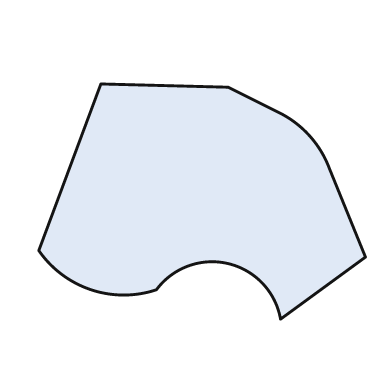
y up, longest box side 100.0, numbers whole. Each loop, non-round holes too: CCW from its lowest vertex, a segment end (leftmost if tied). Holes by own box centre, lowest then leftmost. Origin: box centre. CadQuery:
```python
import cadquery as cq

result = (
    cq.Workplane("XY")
    .moveTo(24.0, -36.0)
    .lineTo(50.0, -17.0)
    .lineTo(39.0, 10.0)
    .threePointArc((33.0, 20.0), (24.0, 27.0))
    .lineTo(8.0, 35.0)
    .lineTo(-31.0, 36.0)
    .lineTo(-50.0, -15.0)
    .threePointArc((-34.0, -27.0), (-14.0, -27.0))
    .threePointArc((8.0, -19.0), (24.0, -36.0))
    .close()
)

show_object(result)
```